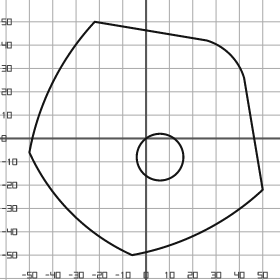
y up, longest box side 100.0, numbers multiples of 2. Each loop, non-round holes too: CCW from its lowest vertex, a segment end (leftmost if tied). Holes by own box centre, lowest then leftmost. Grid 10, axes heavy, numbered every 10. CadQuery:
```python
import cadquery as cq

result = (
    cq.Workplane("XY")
    .moveTo(-6.0, -50.0)
    .threePointArc((24.0, -40.0), (50.0, -22.0))
    .lineTo(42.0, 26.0)
    .threePointArc((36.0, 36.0), (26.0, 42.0))
    .lineTo(-22.0, 50.0)
    .threePointArc((-40.0, 24.0), (-50.0, -6.0))
    .threePointArc((-32.0, -32.0), (-6.0, -50.0))
    .close()
    .moveTo(6.0, -8.0)
    .circle(10.0)
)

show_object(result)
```